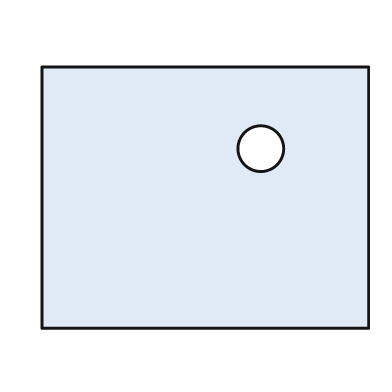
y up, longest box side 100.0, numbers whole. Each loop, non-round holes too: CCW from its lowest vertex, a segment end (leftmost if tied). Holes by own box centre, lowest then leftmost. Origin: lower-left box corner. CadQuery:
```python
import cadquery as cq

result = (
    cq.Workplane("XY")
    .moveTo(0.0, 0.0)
    .lineTo(100.0, 0.0)
    .lineTo(100.0, 80.0)
    .lineTo(0.0, 80.0)
    .close()
    .moveTo(67.0, 55.0)
    .circle(7.0)
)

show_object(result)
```